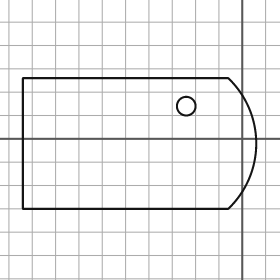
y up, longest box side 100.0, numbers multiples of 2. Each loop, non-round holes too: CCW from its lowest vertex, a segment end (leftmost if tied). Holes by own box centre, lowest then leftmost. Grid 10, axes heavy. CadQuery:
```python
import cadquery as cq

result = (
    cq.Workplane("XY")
    .moveTo(-94.0, -30.0)
    .lineTo(-6.0, -30.0)
    .threePointArc((6.0, -2.0), (-6.0, 26.0))
    .lineTo(-94.0, 26.0)
    .close()
    .moveTo(-24.0, 14.0)
    .circle(4.0)
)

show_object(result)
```